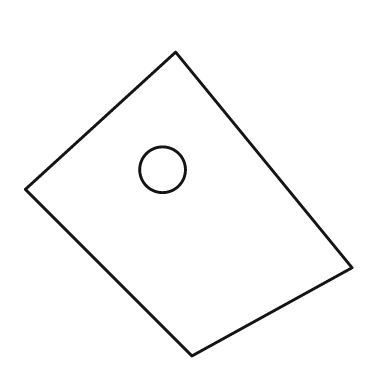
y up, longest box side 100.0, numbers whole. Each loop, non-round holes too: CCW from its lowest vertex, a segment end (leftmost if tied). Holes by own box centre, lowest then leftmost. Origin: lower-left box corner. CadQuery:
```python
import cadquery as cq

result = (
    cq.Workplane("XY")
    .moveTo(51.0, 0.0)
    .lineTo(100.0, 27.0)
    .lineTo(46.0, 93.0)
    .lineTo(0.0, 51.0)
    .close()
    .moveTo(42.0, 57.0)
    .circle(7.0)
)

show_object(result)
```